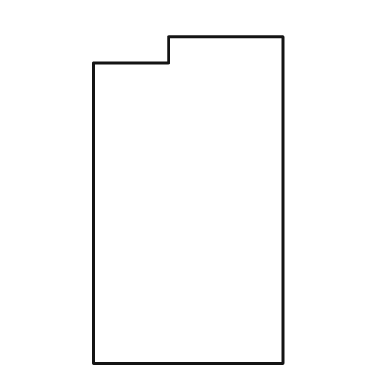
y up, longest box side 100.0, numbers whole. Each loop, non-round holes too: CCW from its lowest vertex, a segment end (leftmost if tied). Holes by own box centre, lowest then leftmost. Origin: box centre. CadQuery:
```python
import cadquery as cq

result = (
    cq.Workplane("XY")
    .moveTo(-29.0, -50.0)
    .lineTo(29.0, -50.0)
    .lineTo(29.0, 50.0)
    .lineTo(-6.0, 50.0)
    .lineTo(-6.0, 42.0)
    .lineTo(-29.0, 42.0)
    .close()
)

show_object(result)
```